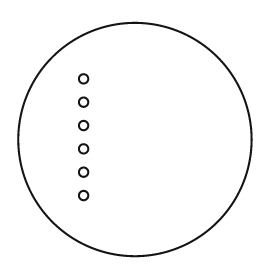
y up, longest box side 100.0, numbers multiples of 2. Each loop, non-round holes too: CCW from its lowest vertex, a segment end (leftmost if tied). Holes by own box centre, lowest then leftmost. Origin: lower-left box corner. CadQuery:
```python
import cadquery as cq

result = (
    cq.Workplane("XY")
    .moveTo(50.0, 50.0)
    .circle(50.0)
    .moveTo(28.0, 26.0)
    .circle(2.0)
    .moveTo(28.0, 36.0)
    .circle(2.0)
    .moveTo(28.0, 46.0)
    .circle(2.0)
    .moveTo(28.0, 56.0)
    .circle(2.0)
    .moveTo(28.0, 66.0)
    .circle(2.0)
    .moveTo(28.0, 76.0)
    .circle(2.0)
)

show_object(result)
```